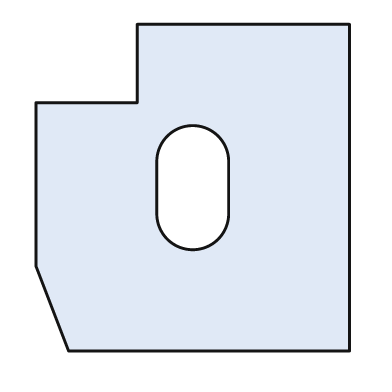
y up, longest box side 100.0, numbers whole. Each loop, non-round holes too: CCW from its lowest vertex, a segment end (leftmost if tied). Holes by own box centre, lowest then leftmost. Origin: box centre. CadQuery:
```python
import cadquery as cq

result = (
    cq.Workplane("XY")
    .moveTo(-38.0, -50.0)
    .lineTo(48.0, -50.0)
    .lineTo(48.0, 50.0)
    .lineTo(-17.0, 50.0)
    .lineTo(-17.0, 26.0)
    .lineTo(-48.0, 26.0)
    .lineTo(-48.0, -24.0)
    .close()
    .moveTo(-11.0, -8.0)
    .threePointArc((0.0, -19.0), (11.0, -8.0))
    .lineTo(11.0, 8.0)
    .threePointArc((0.0, 19.0), (-11.0, 8.0))
    .close()
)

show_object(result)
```